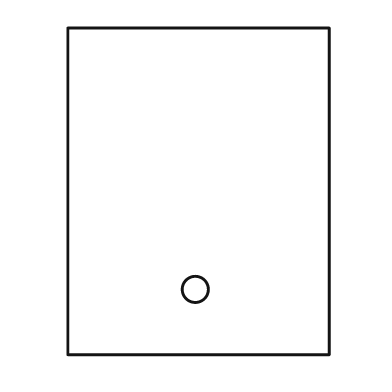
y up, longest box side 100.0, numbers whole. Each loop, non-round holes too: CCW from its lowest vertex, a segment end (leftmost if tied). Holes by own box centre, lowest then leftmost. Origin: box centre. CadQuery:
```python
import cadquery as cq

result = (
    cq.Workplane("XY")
    .moveTo(-40.0, -50.0)
    .lineTo(40.0, -50.0)
    .lineTo(40.0, 50.0)
    .lineTo(-40.0, 50.0)
    .close()
    .moveTo(-1.0, -30.0)
    .circle(4.0)
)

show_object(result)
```